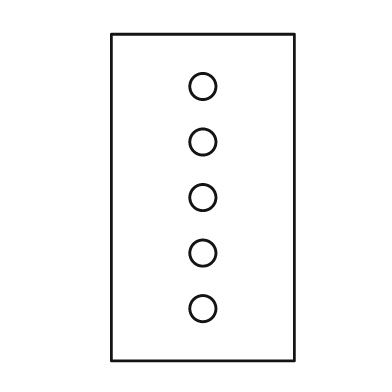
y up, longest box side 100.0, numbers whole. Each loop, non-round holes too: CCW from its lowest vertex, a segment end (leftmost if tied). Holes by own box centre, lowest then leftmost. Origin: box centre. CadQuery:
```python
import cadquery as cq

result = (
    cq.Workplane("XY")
    .moveTo(-28.0, -50.0)
    .lineTo(28.0, -50.0)
    .lineTo(28.0, 50.0)
    .lineTo(-28.0, 50.0)
    .close()
    .moveTo(0.0, -34.0)
    .circle(4.0)
    .moveTo(0.0, -17.0)
    .circle(4.0)
    .moveTo(0.0, 0.0)
    .circle(4.0)
    .moveTo(0.0, 17.0)
    .circle(4.0)
    .moveTo(0.0, 34.0)
    .circle(4.0)
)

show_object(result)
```